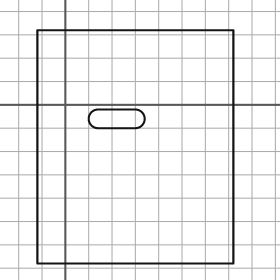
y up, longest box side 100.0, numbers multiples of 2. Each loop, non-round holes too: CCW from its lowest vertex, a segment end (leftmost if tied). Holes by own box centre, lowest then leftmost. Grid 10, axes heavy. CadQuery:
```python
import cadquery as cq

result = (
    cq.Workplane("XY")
    .moveTo(-12.0, -68.0)
    .lineTo(72.0, -68.0)
    .lineTo(72.0, 32.0)
    .lineTo(-12.0, 32.0)
    .close()
    .moveTo(14.0, -10.0)
    .lineTo(30.0, -10.0)
    .threePointArc((34.0, -6.0), (30.0, -2.0))
    .lineTo(14.0, -2.0)
    .threePointArc((10.0, -6.0), (14.0, -10.0))
    .close()
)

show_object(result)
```